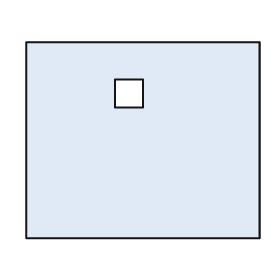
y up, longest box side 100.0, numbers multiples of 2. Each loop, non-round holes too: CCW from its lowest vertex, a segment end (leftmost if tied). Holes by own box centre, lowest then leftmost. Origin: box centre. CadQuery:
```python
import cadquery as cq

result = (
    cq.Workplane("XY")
    .moveTo(-50.0, -42.0)
    .lineTo(50.0, -42.0)
    .lineTo(50.0, 42.0)
    .lineTo(-50.0, 42.0)
    .close()
    .moveTo(-12.0, 14.0)
    .lineTo(0.0, 14.0)
    .lineTo(0.0, 26.0)
    .lineTo(-12.0, 26.0)
    .close()
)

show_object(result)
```